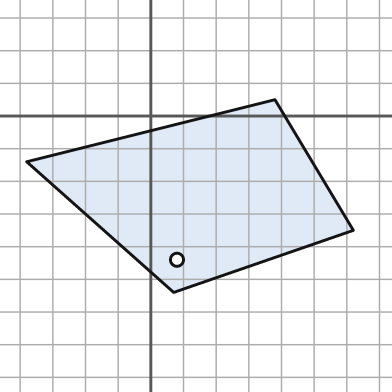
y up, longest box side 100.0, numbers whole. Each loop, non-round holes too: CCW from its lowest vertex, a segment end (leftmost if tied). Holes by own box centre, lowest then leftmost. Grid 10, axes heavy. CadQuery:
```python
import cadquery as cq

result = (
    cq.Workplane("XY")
    .moveTo(7.0, -54.0)
    .lineTo(62.0, -35.0)
    .lineTo(38.0, 5.0)
    .lineTo(-38.0, -14.0)
    .close()
    .moveTo(8.0, -44.0)
    .circle(2.0)
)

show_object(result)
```